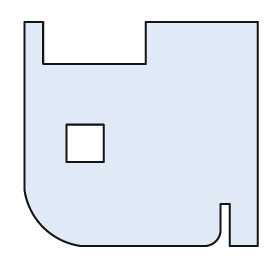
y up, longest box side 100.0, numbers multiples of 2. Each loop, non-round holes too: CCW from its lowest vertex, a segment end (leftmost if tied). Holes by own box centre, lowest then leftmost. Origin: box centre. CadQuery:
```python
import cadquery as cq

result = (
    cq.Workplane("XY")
    .moveTo(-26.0, -48.0)
    .lineTo(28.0, -48.0)
    .threePointArc((32.0, -46.0), (34.0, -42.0))
    .lineTo(34.0, -30.0)
    .lineTo(38.0, -30.0)
    .lineTo(38.0, -48.0)
    .lineTo(50.0, -48.0)
    .lineTo(50.0, 48.0)
    .lineTo(2.0, 48.0)
    .lineTo(2.0, 30.0)
    .lineTo(-42.0, 30.0)
    .lineTo(-42.0, 48.0)
    .lineTo(-50.0, 48.0)
    .lineTo(-50.0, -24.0)
    .threePointArc((-42.0, -40.0), (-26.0, -48.0))
    .close()
    .moveTo(-32.0, -12.0)
    .lineTo(-16.0, -12.0)
    .lineTo(-16.0, 4.0)
    .lineTo(-32.0, 4.0)
    .close()
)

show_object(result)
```